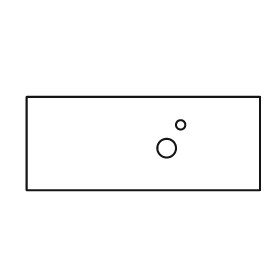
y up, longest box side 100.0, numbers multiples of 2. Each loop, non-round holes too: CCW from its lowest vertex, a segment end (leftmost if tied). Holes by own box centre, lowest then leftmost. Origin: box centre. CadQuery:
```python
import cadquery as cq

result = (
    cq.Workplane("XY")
    .moveTo(-50.0, -20.0)
    .lineTo(50.0, -20.0)
    .lineTo(50.0, 20.0)
    .lineTo(-50.0, 20.0)
    .close()
    .moveTo(10.0, -2.0)
    .circle(4.0)
    .moveTo(16.0, 8.0)
    .circle(2.0)
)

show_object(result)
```